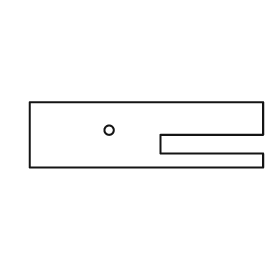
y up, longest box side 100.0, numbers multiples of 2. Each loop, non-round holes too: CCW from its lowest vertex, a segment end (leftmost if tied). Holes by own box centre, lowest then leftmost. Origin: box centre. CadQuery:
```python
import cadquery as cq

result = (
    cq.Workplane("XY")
    .moveTo(-50.0, -14.0)
    .lineTo(50.0, -14.0)
    .lineTo(50.0, -8.0)
    .lineTo(6.0, -8.0)
    .lineTo(6.0, 0.0)
    .lineTo(50.0, 0.0)
    .lineTo(50.0, 14.0)
    .lineTo(-50.0, 14.0)
    .close()
    .moveTo(-16.0, 2.0)
    .circle(2.0)
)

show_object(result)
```